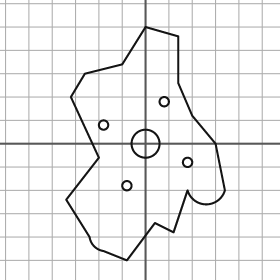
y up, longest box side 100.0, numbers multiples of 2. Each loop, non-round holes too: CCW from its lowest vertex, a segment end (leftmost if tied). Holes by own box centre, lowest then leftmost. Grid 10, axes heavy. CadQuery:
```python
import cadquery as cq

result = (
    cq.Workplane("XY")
    .moveTo(-8.0, -50.0)
    .lineTo(4.0, -34.0)
    .lineTo(12.0, -38.0)
    .lineTo(18.0, -20.0)
    .threePointArc((26.0, -26.0), (34.0, -20.0))
    .lineTo(30.0, 0.0)
    .lineTo(20.0, 12.0)
    .lineTo(14.0, 26.0)
    .lineTo(14.0, 46.0)
    .lineTo(0.0, 50.0)
    .lineTo(-10.0, 34.0)
    .lineTo(-26.0, 30.0)
    .lineTo(-32.0, 20.0)
    .lineTo(-20.0, -6.0)
    .lineTo(-34.0, -24.0)
    .lineTo(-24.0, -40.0)
    .threePointArc((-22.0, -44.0), (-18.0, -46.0))
    .close()
    .moveTo(-8.0, -18.0)
    .circle(2.0)
    .moveTo(18.0, -8.0)
    .circle(2.0)
    .moveTo(0.0, 0.0)
    .circle(6.0)
    .moveTo(-18.0, 8.0)
    .circle(2.0)
    .moveTo(8.0, 18.0)
    .circle(2.0)
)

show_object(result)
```